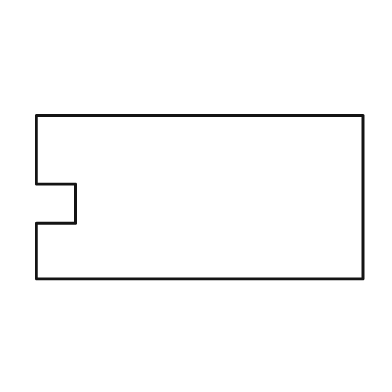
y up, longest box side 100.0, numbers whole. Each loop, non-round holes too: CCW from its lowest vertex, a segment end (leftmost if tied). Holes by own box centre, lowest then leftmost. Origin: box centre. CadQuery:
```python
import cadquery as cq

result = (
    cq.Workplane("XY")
    .moveTo(-50.0, -25.0)
    .lineTo(50.0, -25.0)
    .lineTo(50.0, 25.0)
    .lineTo(-50.0, 25.0)
    .lineTo(-50.0, 4.0)
    .lineTo(-38.0, 4.0)
    .lineTo(-38.0, -8.0)
    .lineTo(-50.0, -8.0)
    .close()
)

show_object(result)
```